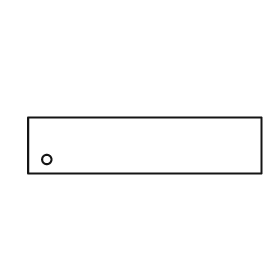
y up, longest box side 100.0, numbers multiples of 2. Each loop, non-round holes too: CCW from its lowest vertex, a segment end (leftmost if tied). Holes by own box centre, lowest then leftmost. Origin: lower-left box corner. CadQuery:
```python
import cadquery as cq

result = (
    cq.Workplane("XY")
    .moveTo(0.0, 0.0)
    .lineTo(100.0, 0.0)
    .lineTo(100.0, 24.0)
    .lineTo(0.0, 24.0)
    .close()
    .moveTo(8.0, 6.0)
    .circle(2.0)
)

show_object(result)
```